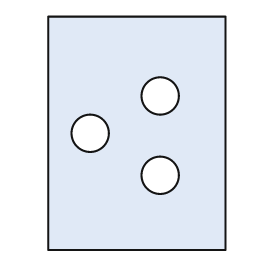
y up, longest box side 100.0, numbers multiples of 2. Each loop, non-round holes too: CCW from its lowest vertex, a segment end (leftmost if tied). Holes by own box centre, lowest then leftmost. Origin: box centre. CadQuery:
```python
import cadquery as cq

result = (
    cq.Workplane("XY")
    .moveTo(-38.0, -50.0)
    .lineTo(38.0, -50.0)
    .lineTo(38.0, 50.0)
    .lineTo(-38.0, 50.0)
    .close()
    .moveTo(10.0, -18.0)
    .circle(8.0)
    .moveTo(-20.0, 0.0)
    .circle(8.0)
    .moveTo(10.0, 16.0)
    .circle(8.0)
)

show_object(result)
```